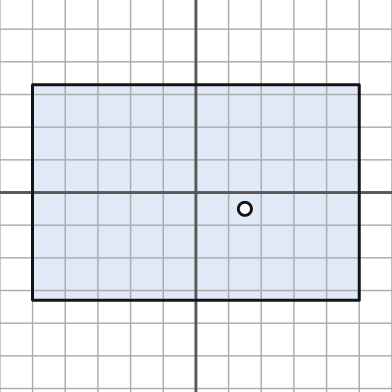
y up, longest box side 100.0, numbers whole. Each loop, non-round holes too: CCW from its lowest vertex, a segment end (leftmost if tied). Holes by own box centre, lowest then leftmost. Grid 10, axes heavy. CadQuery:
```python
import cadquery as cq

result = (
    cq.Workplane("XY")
    .moveTo(-50.0, -33.0)
    .lineTo(50.0, -33.0)
    .lineTo(50.0, 33.0)
    .lineTo(-50.0, 33.0)
    .close()
    .moveTo(15.0, -5.0)
    .circle(2.0)
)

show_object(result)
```